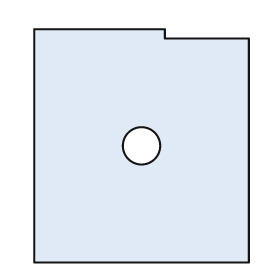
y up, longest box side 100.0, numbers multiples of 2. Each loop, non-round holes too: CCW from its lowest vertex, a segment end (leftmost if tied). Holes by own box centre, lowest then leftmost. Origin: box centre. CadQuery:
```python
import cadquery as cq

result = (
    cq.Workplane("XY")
    .moveTo(-46.0, -50.0)
    .lineTo(46.0, -50.0)
    .lineTo(46.0, 46.0)
    .lineTo(10.0, 46.0)
    .lineTo(10.0, 50.0)
    .lineTo(-46.0, 50.0)
    .close()
    .moveTo(0.0, 0.0)
    .circle(8.0)
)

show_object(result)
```